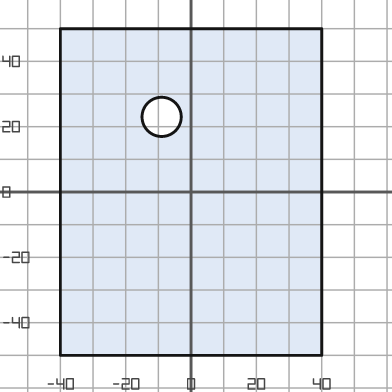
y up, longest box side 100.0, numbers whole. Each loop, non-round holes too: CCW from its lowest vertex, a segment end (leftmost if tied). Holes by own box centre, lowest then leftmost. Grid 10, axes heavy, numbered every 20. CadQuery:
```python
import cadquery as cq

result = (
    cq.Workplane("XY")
    .moveTo(-40.0, -50.0)
    .lineTo(40.0, -50.0)
    .lineTo(40.0, 50.0)
    .lineTo(-40.0, 50.0)
    .close()
    .moveTo(-9.0, 23.0)
    .circle(6.0)
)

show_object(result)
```